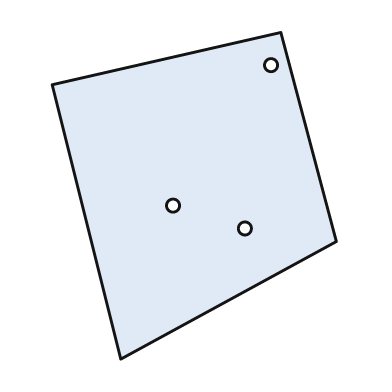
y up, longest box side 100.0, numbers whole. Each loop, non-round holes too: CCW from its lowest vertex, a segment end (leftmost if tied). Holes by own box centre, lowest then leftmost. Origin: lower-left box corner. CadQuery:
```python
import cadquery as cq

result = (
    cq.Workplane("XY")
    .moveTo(21.0, 0.0)
    .lineTo(87.0, 36.0)
    .lineTo(70.0, 100.0)
    .lineTo(0.0, 84.0)
    .close()
    .moveTo(59.0, 40.0)
    .circle(2.0)
    .moveTo(37.0, 47.0)
    .circle(2.0)
    .moveTo(67.0, 90.0)
    .circle(2.0)
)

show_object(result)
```